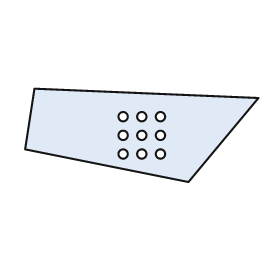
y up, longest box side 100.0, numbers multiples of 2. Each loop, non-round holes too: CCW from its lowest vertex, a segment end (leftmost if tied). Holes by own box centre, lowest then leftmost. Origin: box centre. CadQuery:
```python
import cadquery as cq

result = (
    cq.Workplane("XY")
    .moveTo(20.0, -20.0)
    .lineTo(50.0, 16.0)
    .lineTo(-46.0, 20.0)
    .lineTo(-50.0, -6.0)
    .close()
    .moveTo(-8.0, -8.0)
    .circle(2.0)
    .moveTo(0.0, -8.0)
    .circle(2.0)
    .moveTo(8.0, -8.0)
    .circle(2.0)
    .moveTo(-8.0, 0.0)
    .circle(2.0)
    .moveTo(0.0, 0.0)
    .circle(2.0)
    .moveTo(8.0, 0.0)
    .circle(2.0)
    .moveTo(-8.0, 8.0)
    .circle(2.0)
    .moveTo(0.0, 8.0)
    .circle(2.0)
    .moveTo(8.0, 8.0)
    .circle(2.0)
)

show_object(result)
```